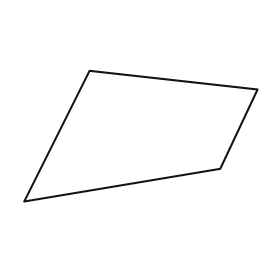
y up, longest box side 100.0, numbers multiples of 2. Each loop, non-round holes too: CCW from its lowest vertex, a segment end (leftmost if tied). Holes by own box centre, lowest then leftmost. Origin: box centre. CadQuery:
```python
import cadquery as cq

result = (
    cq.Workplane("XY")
    .moveTo(-50.0, -28.0)
    .lineTo(34.0, -14.0)
    .lineTo(50.0, 20.0)
    .lineTo(-22.0, 28.0)
    .close()
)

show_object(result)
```